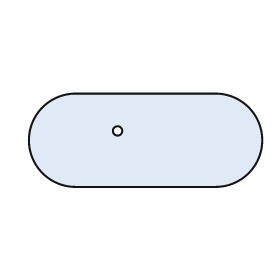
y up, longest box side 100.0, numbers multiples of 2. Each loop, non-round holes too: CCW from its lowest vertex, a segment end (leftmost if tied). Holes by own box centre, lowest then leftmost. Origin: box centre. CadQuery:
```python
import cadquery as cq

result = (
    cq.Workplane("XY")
    .moveTo(-30.0, -20.0)
    .lineTo(30.0, -20.0)
    .threePointArc((50.0, 0.0), (30.0, 20.0))
    .lineTo(-30.0, 20.0)
    .threePointArc((-50.0, 0.0), (-30.0, -20.0))
    .close()
    .moveTo(-12.0, 4.0)
    .circle(2.0)
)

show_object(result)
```